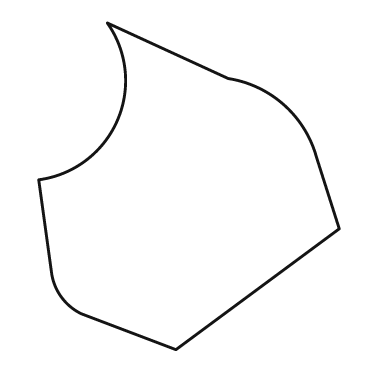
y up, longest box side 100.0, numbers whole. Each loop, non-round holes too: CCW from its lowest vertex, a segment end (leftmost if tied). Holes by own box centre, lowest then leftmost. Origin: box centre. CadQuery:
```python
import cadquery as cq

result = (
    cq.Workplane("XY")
    .moveTo(-4.0, -50.0)
    .lineTo(46.0, -13.0)
    .lineTo(39.0, 9.0)
    .threePointArc((29.0, 25.0), (12.0, 33.0))
    .lineTo(-25.0, 50.0)
    .threePointArc((-22.0, 20.0), (-46.0, 2.0))
    .lineTo(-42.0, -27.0)
    .threePointArc((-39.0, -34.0), (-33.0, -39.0))
    .close()
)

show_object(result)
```